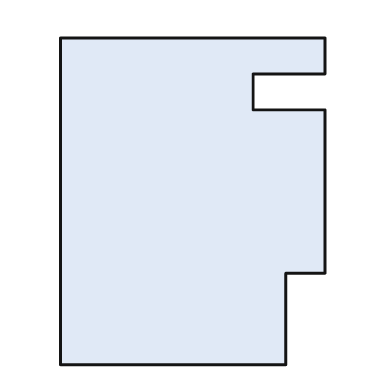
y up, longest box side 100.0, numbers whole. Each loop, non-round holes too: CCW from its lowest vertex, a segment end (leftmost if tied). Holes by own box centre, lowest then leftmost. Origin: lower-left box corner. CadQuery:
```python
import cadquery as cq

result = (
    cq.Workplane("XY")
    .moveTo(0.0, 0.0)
    .lineTo(69.0, 0.0)
    .lineTo(69.0, 28.0)
    .lineTo(81.0, 28.0)
    .lineTo(81.0, 78.0)
    .lineTo(59.0, 78.0)
    .lineTo(59.0, 89.0)
    .lineTo(81.0, 89.0)
    .lineTo(81.0, 100.0)
    .lineTo(0.0, 100.0)
    .close()
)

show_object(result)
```